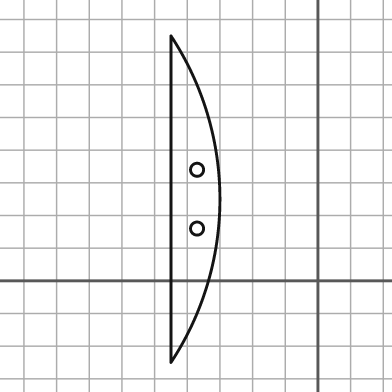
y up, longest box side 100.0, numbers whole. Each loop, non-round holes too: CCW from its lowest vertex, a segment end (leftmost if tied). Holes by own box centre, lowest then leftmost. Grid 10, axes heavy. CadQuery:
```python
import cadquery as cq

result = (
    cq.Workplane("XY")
    .moveTo(-45.0, -25.0)
    .threePointArc((-30.0, 25.0), (-45.0, 75.0))
    .close()
    .moveTo(-37.0, 16.0)
    .circle(2.0)
    .moveTo(-37.0, 34.0)
    .circle(2.0)
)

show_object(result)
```